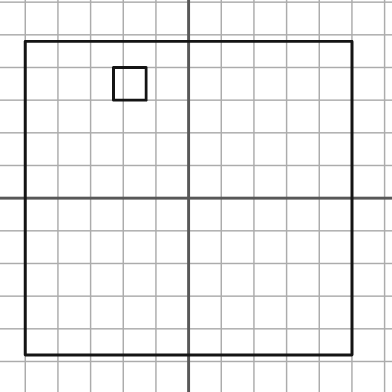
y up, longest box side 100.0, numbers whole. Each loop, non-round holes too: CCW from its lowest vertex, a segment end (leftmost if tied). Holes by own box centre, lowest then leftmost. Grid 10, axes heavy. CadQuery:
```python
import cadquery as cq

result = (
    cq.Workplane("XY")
    .moveTo(-50.0, -48.0)
    .lineTo(50.0, -48.0)
    .lineTo(50.0, 48.0)
    .lineTo(-50.0, 48.0)
    .close()
    .moveTo(-23.0, 30.0)
    .lineTo(-13.0, 30.0)
    .lineTo(-13.0, 40.0)
    .lineTo(-23.0, 40.0)
    .close()
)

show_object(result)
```